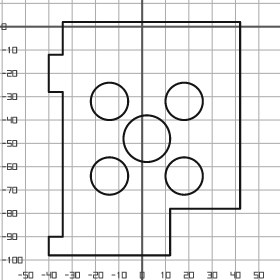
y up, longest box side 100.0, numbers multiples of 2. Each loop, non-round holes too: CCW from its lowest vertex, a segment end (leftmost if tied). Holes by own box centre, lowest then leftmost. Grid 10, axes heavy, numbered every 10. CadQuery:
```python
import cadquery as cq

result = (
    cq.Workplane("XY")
    .moveTo(-40.0, -98.0)
    .lineTo(12.0, -98.0)
    .lineTo(12.0, -78.0)
    .lineTo(42.0, -78.0)
    .lineTo(42.0, 2.0)
    .lineTo(-34.0, 2.0)
    .lineTo(-34.0, -12.0)
    .lineTo(-40.0, -12.0)
    .lineTo(-40.0, -28.0)
    .lineTo(-34.0, -28.0)
    .lineTo(-34.0, -90.0)
    .lineTo(-40.0, -90.0)
    .close()
    .moveTo(-14.0, -64.0)
    .circle(8.0)
    .moveTo(18.0, -64.0)
    .circle(8.0)
    .moveTo(2.0, -48.0)
    .circle(10.0)
    .moveTo(-14.0, -32.0)
    .circle(8.0)
    .moveTo(18.0, -32.0)
    .circle(8.0)
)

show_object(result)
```